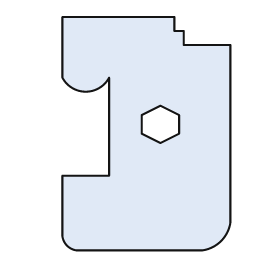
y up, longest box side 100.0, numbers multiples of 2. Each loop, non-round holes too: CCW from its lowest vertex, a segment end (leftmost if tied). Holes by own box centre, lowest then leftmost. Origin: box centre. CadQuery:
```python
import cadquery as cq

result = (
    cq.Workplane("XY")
    .moveTo(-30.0, -50.0)
    .lineTo(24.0, -50.0)
    .threePointArc((32.0, -46.0), (36.0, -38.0))
    .lineTo(36.0, 38.0)
    .lineTo(16.0, 38.0)
    .lineTo(16.0, 44.0)
    .lineTo(12.0, 44.0)
    .lineTo(12.0, 50.0)
    .lineTo(-36.0, 50.0)
    .lineTo(-36.0, 24.0)
    .threePointArc((-26.0, 18.0), (-16.0, 24.0))
    .lineTo(-16.0, -18.0)
    .lineTo(-36.0, -18.0)
    .lineTo(-36.0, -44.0)
    .threePointArc((-34.0, -48.0), (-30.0, -50.0))
    .close()
    .moveTo(6.0, -4.0)
    .lineTo(14.0, 0.0)
    .lineTo(14.0, 8.0)
    .lineTo(6.0, 12.0)
    .lineTo(-2.0, 8.0)
    .lineTo(-2.0, 0.0)
    .close()
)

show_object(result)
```